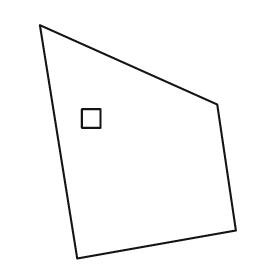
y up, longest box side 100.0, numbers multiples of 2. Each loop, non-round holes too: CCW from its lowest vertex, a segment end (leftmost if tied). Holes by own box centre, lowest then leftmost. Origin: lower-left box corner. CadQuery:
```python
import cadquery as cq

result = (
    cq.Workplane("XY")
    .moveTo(16.0, 0.0)
    .lineTo(84.0, 12.0)
    .lineTo(76.0, 66.0)
    .lineTo(0.0, 100.0)
    .close()
    .moveTo(18.0, 56.0)
    .lineTo(26.0, 56.0)
    .lineTo(26.0, 64.0)
    .lineTo(18.0, 64.0)
    .close()
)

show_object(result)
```